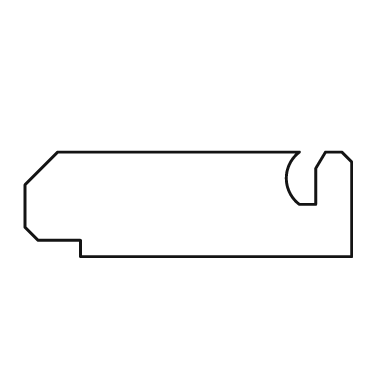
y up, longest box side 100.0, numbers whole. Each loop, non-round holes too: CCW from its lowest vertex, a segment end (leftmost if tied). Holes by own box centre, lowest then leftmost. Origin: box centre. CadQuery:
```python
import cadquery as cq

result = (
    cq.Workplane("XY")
    .moveTo(-33.0, -16.0)
    .lineTo(50.0, -16.0)
    .lineTo(50.0, 13.0)
    .lineTo(47.0, 16.0)
    .lineTo(42.0, 16.0)
    .lineTo(39.0, 11.0)
    .lineTo(39.0, 0.0)
    .lineTo(34.0, 0.0)
    .threePointArc((30.0, 8.0), (34.0, 16.0))
    .lineTo(-40.0, 16.0)
    .lineTo(-50.0, 6.0)
    .lineTo(-50.0, -7.0)
    .lineTo(-46.0, -11.0)
    .lineTo(-33.0, -11.0)
    .close()
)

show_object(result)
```